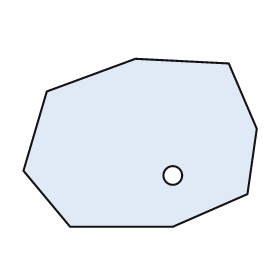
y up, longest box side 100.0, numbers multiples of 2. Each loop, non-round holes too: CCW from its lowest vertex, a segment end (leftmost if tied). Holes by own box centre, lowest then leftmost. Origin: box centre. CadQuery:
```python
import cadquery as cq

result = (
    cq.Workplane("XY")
    .moveTo(-30.0, -36.0)
    .lineTo(14.0, -36.0)
    .lineTo(46.0, -22.0)
    .lineTo(50.0, 6.0)
    .lineTo(38.0, 34.0)
    .lineTo(-2.0, 36.0)
    .lineTo(-40.0, 22.0)
    .lineTo(-50.0, -12.0)
    .close()
    .moveTo(14.0, -14.0)
    .circle(4.0)
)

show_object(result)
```